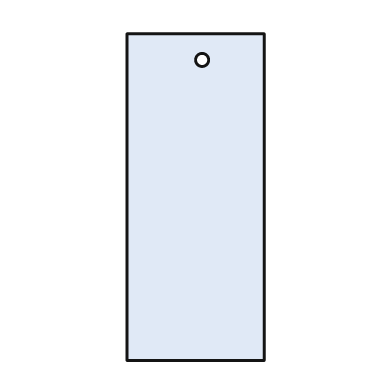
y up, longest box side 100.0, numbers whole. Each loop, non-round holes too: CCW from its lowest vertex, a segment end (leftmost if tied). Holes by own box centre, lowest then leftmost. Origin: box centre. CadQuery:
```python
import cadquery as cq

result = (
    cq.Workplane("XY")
    .moveTo(-21.0, -50.0)
    .lineTo(21.0, -50.0)
    .lineTo(21.0, 50.0)
    .lineTo(-21.0, 50.0)
    .close()
    .moveTo(2.0, 42.0)
    .circle(2.0)
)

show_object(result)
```